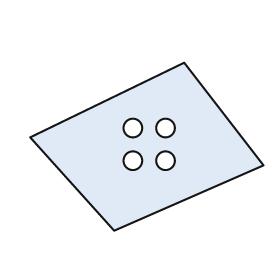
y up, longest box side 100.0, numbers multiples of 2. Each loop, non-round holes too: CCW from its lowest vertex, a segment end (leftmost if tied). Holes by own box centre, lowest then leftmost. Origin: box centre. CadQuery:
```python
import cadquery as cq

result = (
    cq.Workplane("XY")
    .moveTo(-14.0, -36.0)
    .lineTo(50.0, -8.0)
    .lineTo(16.0, 36.0)
    .lineTo(-50.0, 4.0)
    .close()
    .moveTo(-6.0, -6.0)
    .circle(4.0)
    .moveTo(8.0, -6.0)
    .circle(4.0)
    .moveTo(-6.0, 8.0)
    .circle(4.0)
    .moveTo(8.0, 8.0)
    .circle(4.0)
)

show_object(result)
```